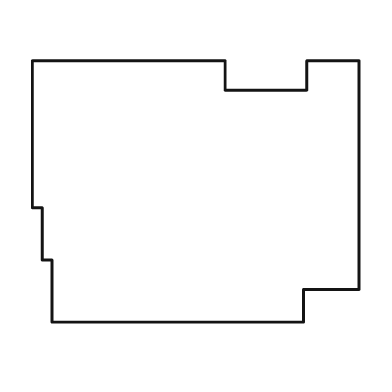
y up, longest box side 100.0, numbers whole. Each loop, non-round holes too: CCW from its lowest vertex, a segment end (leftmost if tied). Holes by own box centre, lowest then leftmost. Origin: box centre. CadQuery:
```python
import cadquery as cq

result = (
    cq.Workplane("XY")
    .moveTo(-44.0, -40.0)
    .lineTo(33.0, -40.0)
    .lineTo(33.0, -30.0)
    .lineTo(50.0, -30.0)
    .lineTo(50.0, 40.0)
    .lineTo(34.0, 40.0)
    .lineTo(34.0, 31.0)
    .lineTo(9.0, 31.0)
    .lineTo(9.0, 40.0)
    .lineTo(-50.0, 40.0)
    .lineTo(-50.0, -5.0)
    .lineTo(-47.0, -5.0)
    .lineTo(-47.0, -21.0)
    .lineTo(-44.0, -21.0)
    .close()
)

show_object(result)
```